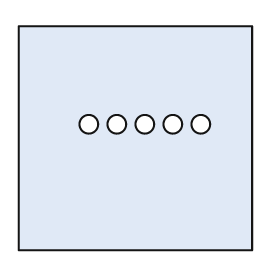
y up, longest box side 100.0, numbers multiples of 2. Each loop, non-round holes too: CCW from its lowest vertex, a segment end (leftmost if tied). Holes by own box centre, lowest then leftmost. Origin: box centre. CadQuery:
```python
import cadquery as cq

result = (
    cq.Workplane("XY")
    .moveTo(-50.0, -48.0)
    .lineTo(50.0, -48.0)
    .lineTo(50.0, 48.0)
    .lineTo(-50.0, 48.0)
    .close()
    .moveTo(-20.0, 6.0)
    .circle(4.0)
    .moveTo(-8.0, 6.0)
    .circle(4.0)
    .moveTo(4.0, 6.0)
    .circle(4.0)
    .moveTo(16.0, 6.0)
    .circle(4.0)
    .moveTo(28.0, 6.0)
    .circle(4.0)
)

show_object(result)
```